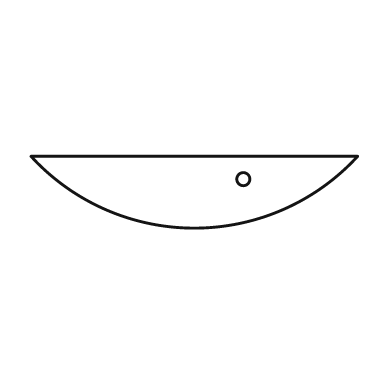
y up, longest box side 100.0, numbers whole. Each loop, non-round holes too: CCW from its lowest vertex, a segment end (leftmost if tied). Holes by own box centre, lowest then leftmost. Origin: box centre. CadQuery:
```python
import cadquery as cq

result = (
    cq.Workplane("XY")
    .moveTo(-50.0, 11.0)
    .threePointArc((0.0, -11.0), (50.0, 11.0))
    .close()
    .moveTo(15.0, 4.0)
    .circle(2.0)
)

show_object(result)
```